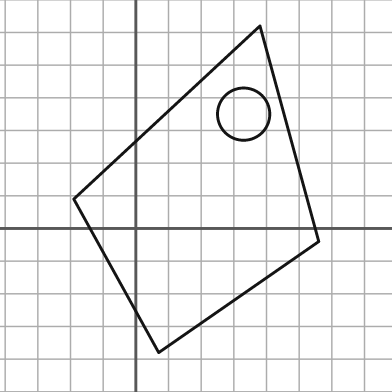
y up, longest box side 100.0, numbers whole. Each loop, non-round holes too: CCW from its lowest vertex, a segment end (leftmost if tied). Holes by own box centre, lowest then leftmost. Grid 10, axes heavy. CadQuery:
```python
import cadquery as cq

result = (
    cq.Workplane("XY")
    .moveTo(7.0, -38.0)
    .lineTo(56.0, -4.0)
    .lineTo(38.0, 62.0)
    .lineTo(-19.0, 9.0)
    .close()
    .moveTo(33.0, 35.0)
    .circle(8.0)
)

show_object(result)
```